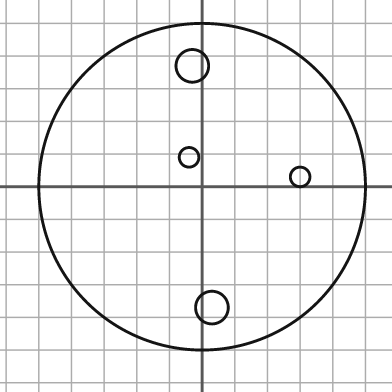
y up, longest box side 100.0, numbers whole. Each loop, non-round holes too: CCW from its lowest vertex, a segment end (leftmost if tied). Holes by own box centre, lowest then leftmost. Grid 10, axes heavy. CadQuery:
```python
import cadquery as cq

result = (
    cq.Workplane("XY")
    .moveTo(0.0, 0.0)
    .circle(50.0)
    .moveTo(3.0, -37.0)
    .circle(5.0)
    .moveTo(30.0, 3.0)
    .circle(3.0)
    .moveTo(-4.0, 9.0)
    .circle(3.0)
    .moveTo(-3.0, 37.0)
    .circle(5.0)
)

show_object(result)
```